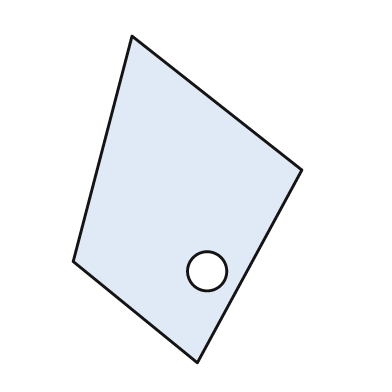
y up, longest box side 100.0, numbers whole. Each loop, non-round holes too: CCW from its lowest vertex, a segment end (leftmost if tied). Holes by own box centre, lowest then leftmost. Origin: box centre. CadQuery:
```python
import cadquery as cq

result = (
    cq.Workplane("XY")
    .moveTo(3.0, -50.0)
    .lineTo(35.0, 9.0)
    .lineTo(-17.0, 50.0)
    .lineTo(-35.0, -19.0)
    .close()
    .moveTo(6.0, -22.0)
    .circle(6.0)
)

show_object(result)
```